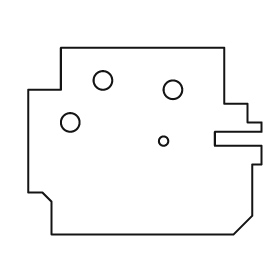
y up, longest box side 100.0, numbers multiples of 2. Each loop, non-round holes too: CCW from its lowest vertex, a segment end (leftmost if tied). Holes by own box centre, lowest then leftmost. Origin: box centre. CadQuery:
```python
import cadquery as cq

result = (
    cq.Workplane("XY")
    .moveTo(-40.0, -40.0)
    .lineTo(38.0, -40.0)
    .lineTo(46.0, -32.0)
    .lineTo(46.0, -10.0)
    .lineTo(50.0, -10.0)
    .lineTo(50.0, -2.0)
    .lineTo(30.0, -2.0)
    .lineTo(30.0, 4.0)
    .lineTo(50.0, 4.0)
    .lineTo(50.0, 8.0)
    .lineTo(44.0, 8.0)
    .lineTo(44.0, 16.0)
    .lineTo(34.0, 16.0)
    .lineTo(34.0, 40.0)
    .lineTo(-36.0, 40.0)
    .lineTo(-36.0, 22.0)
    .lineTo(-50.0, 22.0)
    .lineTo(-50.0, -22.0)
    .lineTo(-44.0, -22.0)
    .lineTo(-40.0, -26.0)
    .close()
    .moveTo(8.0, 0.0)
    .circle(2.0)
    .moveTo(-32.0, 8.0)
    .circle(4.0)
    .moveTo(12.0, 22.0)
    .circle(4.0)
    .moveTo(-18.0, 26.0)
    .circle(4.0)
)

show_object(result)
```